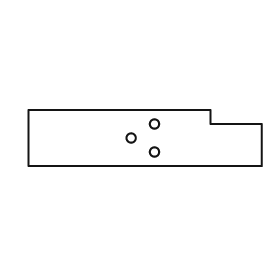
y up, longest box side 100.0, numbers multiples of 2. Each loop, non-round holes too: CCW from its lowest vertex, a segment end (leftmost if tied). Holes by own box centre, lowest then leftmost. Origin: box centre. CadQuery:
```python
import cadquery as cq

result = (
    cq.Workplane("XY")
    .moveTo(-50.0, -12.0)
    .lineTo(50.0, -12.0)
    .lineTo(50.0, 6.0)
    .lineTo(28.0, 6.0)
    .lineTo(28.0, 12.0)
    .lineTo(-50.0, 12.0)
    .close()
    .moveTo(4.0, -6.0)
    .circle(2.0)
    .moveTo(-6.0, 0.0)
    .circle(2.0)
    .moveTo(4.0, 6.0)
    .circle(2.0)
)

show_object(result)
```